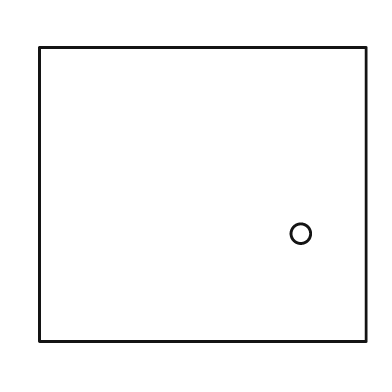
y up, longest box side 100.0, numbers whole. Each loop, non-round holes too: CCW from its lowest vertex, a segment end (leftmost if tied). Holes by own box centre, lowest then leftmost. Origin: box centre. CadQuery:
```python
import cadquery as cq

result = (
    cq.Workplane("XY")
    .moveTo(-50.0, -45.0)
    .lineTo(50.0, -45.0)
    .lineTo(50.0, 45.0)
    .lineTo(-50.0, 45.0)
    .close()
    .moveTo(30.0, -12.0)
    .circle(3.0)
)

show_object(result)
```